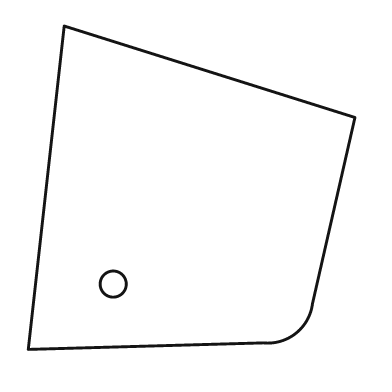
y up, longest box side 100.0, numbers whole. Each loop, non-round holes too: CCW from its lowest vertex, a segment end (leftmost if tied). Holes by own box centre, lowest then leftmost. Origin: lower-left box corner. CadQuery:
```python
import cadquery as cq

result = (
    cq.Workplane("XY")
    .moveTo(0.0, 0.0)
    .lineTo(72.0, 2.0)
    .threePointArc((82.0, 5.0), (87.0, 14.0))
    .lineTo(100.0, 71.0)
    .lineTo(11.0, 99.0)
    .close()
    .moveTo(26.0, 20.0)
    .circle(4.0)
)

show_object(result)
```